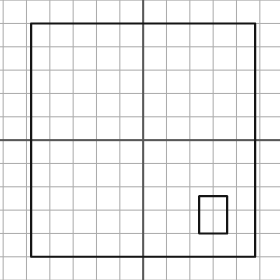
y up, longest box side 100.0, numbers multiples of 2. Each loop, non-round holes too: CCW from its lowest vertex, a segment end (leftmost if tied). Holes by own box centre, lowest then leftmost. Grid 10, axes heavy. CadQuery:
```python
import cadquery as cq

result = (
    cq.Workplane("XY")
    .moveTo(-48.0, -50.0)
    .lineTo(48.0, -50.0)
    .lineTo(48.0, 50.0)
    .lineTo(-48.0, 50.0)
    .close()
    .moveTo(24.0, -40.0)
    .lineTo(36.0, -40.0)
    .lineTo(36.0, -24.0)
    .lineTo(24.0, -24.0)
    .close()
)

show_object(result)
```